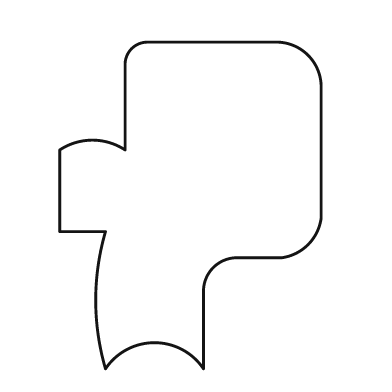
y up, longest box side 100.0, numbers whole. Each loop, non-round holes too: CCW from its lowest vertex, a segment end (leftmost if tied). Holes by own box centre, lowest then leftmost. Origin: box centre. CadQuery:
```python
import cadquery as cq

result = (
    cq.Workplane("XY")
    .moveTo(-26.0, -50.0)
    .threePointArc((-11.0, -42.0), (4.0, -50.0))
    .lineTo(4.0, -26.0)
    .threePointArc((7.0, -19.0), (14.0, -16.0))
    .lineTo(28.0, -16.0)
    .threePointArc((36.0, -12.0), (40.0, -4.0))
    .lineTo(40.0, 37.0)
    .threePointArc((36.0, 46.0), (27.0, 50.0))
    .lineTo(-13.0, 50.0)
    .threePointArc((-18.0, 48.0), (-20.0, 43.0))
    .lineTo(-20.0, 17.0)
    .threePointArc((-30.0, 20.0), (-40.0, 17.0))
    .lineTo(-40.0, -8.0)
    .lineTo(-26.0, -8.0)
    .threePointArc((-29.0, -29.0), (-26.0, -50.0))
    .close()
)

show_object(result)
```